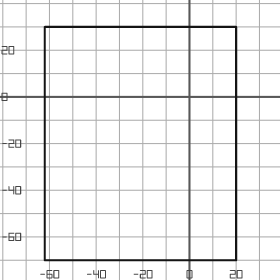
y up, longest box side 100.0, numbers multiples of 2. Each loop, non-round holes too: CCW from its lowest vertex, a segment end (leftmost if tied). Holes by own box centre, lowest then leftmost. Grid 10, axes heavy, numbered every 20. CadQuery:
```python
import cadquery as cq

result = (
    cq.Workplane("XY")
    .moveTo(-62.0, -70.0)
    .lineTo(20.0, -70.0)
    .lineTo(20.0, 30.0)
    .lineTo(-62.0, 30.0)
    .close()
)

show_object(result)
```